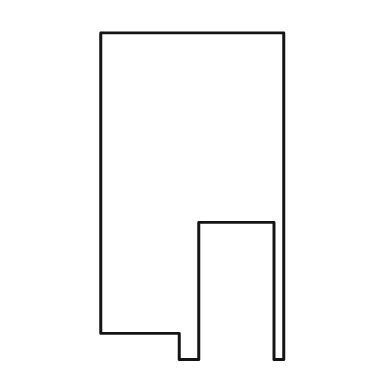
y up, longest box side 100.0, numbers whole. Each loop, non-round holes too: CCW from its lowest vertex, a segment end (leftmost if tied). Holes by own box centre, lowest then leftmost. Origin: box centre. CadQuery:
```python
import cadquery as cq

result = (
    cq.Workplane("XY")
    .moveTo(-4.0, -50.0)
    .lineTo(2.0, -50.0)
    .lineTo(2.0, -8.0)
    .lineTo(25.0, -8.0)
    .lineTo(25.0, -50.0)
    .lineTo(28.0, -50.0)
    .lineTo(28.0, 50.0)
    .lineTo(-28.0, 50.0)
    .lineTo(-28.0, -42.0)
    .lineTo(-4.0, -42.0)
    .close()
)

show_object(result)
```